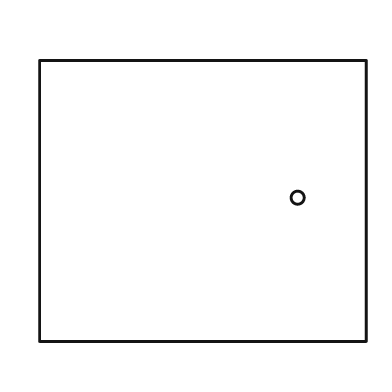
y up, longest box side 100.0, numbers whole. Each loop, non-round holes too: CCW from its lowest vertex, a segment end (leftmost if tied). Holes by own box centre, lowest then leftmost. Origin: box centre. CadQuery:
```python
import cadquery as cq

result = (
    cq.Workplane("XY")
    .moveTo(-50.0, -43.0)
    .lineTo(50.0, -43.0)
    .lineTo(50.0, 43.0)
    .lineTo(-50.0, 43.0)
    .close()
    .moveTo(29.0, 1.0)
    .circle(2.0)
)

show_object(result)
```